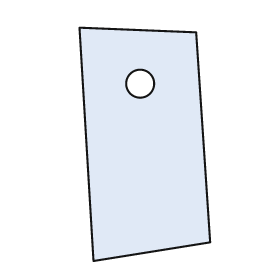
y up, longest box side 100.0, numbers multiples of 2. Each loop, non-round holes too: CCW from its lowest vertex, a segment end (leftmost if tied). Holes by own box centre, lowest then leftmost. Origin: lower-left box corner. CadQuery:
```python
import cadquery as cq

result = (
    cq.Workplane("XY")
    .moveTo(6.0, 0.0)
    .lineTo(56.0, 8.0)
    .lineTo(50.0, 98.0)
    .lineTo(0.0, 100.0)
    .close()
    .moveTo(26.0, 76.0)
    .circle(6.0)
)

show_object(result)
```